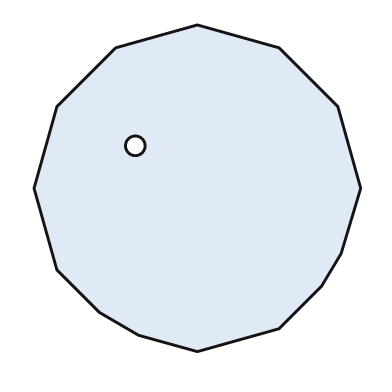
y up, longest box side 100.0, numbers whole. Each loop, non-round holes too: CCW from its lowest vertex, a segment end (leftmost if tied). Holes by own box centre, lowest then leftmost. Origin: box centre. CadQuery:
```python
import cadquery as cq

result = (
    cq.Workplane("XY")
    .moveTo(0.0, -50.0)
    .lineTo(25.0, -43.0)
    .lineTo(38.0, -30.0)
    .lineTo(44.0, -20.0)
    .lineTo(50.0, 0.0)
    .lineTo(43.0, 25.0)
    .lineTo(25.0, 43.0)
    .lineTo(0.0, 50.0)
    .lineTo(-25.0, 43.0)
    .lineTo(-43.0, 25.0)
    .lineTo(-50.0, 0.0)
    .lineTo(-43.0, -25.0)
    .lineTo(-30.0, -38.0)
    .lineTo(-18.0, -45.0)
    .close()
    .moveTo(-19.0, 13.0)
    .circle(3.0)
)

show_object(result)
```